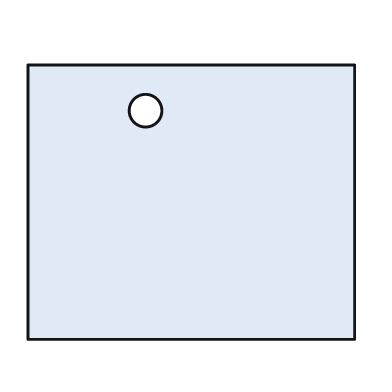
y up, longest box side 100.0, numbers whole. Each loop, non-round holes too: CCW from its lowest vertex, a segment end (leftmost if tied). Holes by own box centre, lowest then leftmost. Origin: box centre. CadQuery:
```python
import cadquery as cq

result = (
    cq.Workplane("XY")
    .moveTo(-50.0, -42.0)
    .lineTo(50.0, -42.0)
    .lineTo(50.0, 42.0)
    .lineTo(-50.0, 42.0)
    .close()
    .moveTo(-14.0, 28.0)
    .circle(5.0)
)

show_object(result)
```